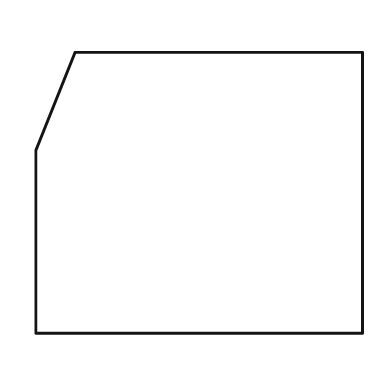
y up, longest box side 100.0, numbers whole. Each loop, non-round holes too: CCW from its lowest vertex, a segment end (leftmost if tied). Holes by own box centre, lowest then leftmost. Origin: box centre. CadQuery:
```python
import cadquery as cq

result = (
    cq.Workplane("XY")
    .moveTo(-50.0, -43.0)
    .lineTo(50.0, -43.0)
    .lineTo(50.0, 43.0)
    .lineTo(-38.0, 43.0)
    .lineTo(-50.0, 13.0)
    .close()
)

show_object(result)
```